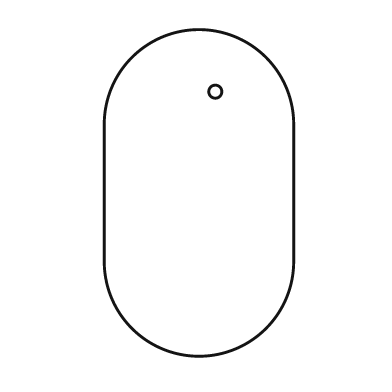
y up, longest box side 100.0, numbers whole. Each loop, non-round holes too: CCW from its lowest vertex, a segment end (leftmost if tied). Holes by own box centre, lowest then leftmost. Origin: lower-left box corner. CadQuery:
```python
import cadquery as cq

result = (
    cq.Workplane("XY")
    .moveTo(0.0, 29.0)
    .threePointArc((29.0, 0.0), (58.0, 29.0))
    .lineTo(58.0, 71.0)
    .threePointArc((29.0, 100.0), (0.0, 71.0))
    .close()
    .moveTo(34.0, 81.0)
    .circle(2.0)
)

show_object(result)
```